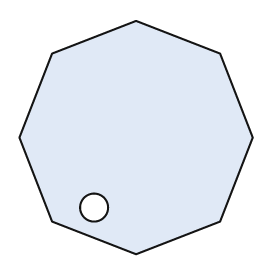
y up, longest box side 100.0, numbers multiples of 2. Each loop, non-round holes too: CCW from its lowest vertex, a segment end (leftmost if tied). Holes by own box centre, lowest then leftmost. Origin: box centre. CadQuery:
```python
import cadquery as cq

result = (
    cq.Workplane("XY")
    .moveTo(0.0, -50.0)
    .lineTo(36.0, -36.0)
    .lineTo(50.0, 0.0)
    .lineTo(36.0, 36.0)
    .lineTo(0.0, 50.0)
    .lineTo(-36.0, 36.0)
    .lineTo(-50.0, 0.0)
    .lineTo(-36.0, -36.0)
    .close()
    .moveTo(-18.0, -30.0)
    .circle(6.0)
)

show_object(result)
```